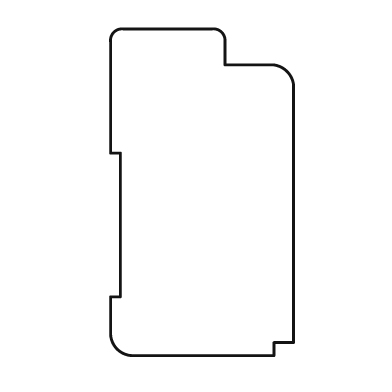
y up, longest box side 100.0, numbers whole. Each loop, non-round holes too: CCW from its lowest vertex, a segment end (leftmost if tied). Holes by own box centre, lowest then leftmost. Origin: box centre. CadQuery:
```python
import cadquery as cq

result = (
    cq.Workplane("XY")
    .moveTo(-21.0, -50.0)
    .lineTo(22.0, -50.0)
    .lineTo(22.0, -46.0)
    .lineTo(28.0, -46.0)
    .lineTo(28.0, 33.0)
    .threePointArc((26.0, 37.0), (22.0, 39.0))
    .lineTo(7.0, 39.0)
    .lineTo(7.0, 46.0)
    .threePointArc((6.0, 49.0), (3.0, 50.0))
    .lineTo(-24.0, 50.0)
    .threePointArc((-27.0, 49.0), (-28.0, 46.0))
    .lineTo(-28.0, 12.0)
    .lineTo(-25.0, 12.0)
    .lineTo(-25.0, -32.0)
    .lineTo(-28.0, -32.0)
    .lineTo(-28.0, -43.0)
    .threePointArc((-26.0, -48.0), (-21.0, -50.0))
    .close()
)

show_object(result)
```